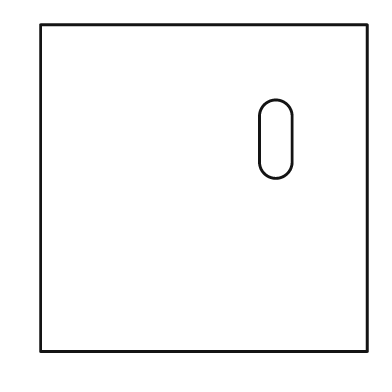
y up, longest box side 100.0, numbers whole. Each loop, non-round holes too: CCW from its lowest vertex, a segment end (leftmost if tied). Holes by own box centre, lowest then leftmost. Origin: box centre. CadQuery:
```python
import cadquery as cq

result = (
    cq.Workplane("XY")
    .moveTo(-50.0, -50.0)
    .lineTo(50.0, -50.0)
    .lineTo(50.0, 50.0)
    .lineTo(-50.0, 50.0)
    .close()
    .moveTo(17.0, 8.0)
    .threePointArc((22.0, 3.0), (27.0, 8.0))
    .lineTo(27.0, 22.0)
    .threePointArc((22.0, 27.0), (17.0, 22.0))
    .close()
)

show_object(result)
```